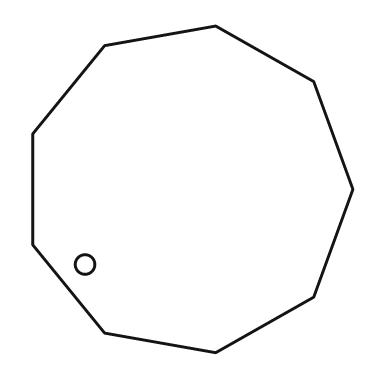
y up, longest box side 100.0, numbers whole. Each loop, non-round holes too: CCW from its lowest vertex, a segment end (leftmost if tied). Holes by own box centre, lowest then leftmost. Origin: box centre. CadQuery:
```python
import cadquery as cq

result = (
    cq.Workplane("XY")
    .moveTo(7.0, -50.0)
    .lineTo(37.0, -33.0)
    .lineTo(49.0, 0.0)
    .lineTo(37.0, 33.0)
    .lineTo(7.0, 50.0)
    .lineTo(-27.0, 44.0)
    .lineTo(-49.0, 17.0)
    .lineTo(-49.0, -17.0)
    .lineTo(-27.0, -44.0)
    .close()
    .moveTo(-33.0, -23.0)
    .circle(3.0)
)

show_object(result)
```